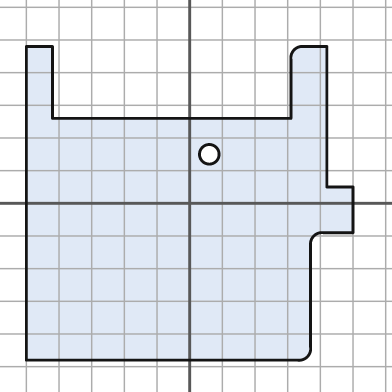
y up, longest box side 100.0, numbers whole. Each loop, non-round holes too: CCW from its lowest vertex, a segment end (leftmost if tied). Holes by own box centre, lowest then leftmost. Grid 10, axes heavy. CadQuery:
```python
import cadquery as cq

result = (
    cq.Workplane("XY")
    .moveTo(-50.0, -48.0)
    .lineTo(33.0, -48.0)
    .threePointArc((36.0, -47.0), (37.0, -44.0))
    .lineTo(37.0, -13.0)
    .threePointArc((38.0, -10.0), (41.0, -9.0))
    .lineTo(50.0, -9.0)
    .lineTo(50.0, 5.0)
    .lineTo(42.0, 5.0)
    .lineTo(42.0, 48.0)
    .lineTo(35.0, 48.0)
    .threePointArc((32.0, 47.0), (31.0, 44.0))
    .lineTo(31.0, 26.0)
    .lineTo(-42.0, 26.0)
    .lineTo(-42.0, 48.0)
    .lineTo(-50.0, 48.0)
    .close()
    .moveTo(6.0, 15.0)
    .circle(3.0)
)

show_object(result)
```